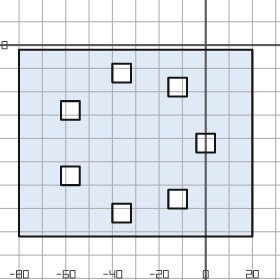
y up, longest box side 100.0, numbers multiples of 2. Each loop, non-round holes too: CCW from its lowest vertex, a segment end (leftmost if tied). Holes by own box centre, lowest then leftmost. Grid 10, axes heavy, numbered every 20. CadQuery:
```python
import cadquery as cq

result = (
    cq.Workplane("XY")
    .moveTo(-80.0, -82.0)
    .lineTo(20.0, -82.0)
    .lineTo(20.0, -2.0)
    .lineTo(-80.0, -2.0)
    .close()
    .moveTo(-40.0, -76.0)
    .lineTo(-32.0, -76.0)
    .lineTo(-32.0, -68.0)
    .lineTo(-40.0, -68.0)
    .close()
    .moveTo(-16.0, -70.0)
    .lineTo(-8.0, -70.0)
    .lineTo(-8.0, -62.0)
    .lineTo(-16.0, -62.0)
    .close()
    .moveTo(-62.0, -60.0)
    .lineTo(-54.0, -60.0)
    .lineTo(-54.0, -52.0)
    .lineTo(-62.0, -52.0)
    .close()
    .moveTo(-4.0, -46.0)
    .lineTo(4.0, -46.0)
    .lineTo(4.0, -38.0)
    .lineTo(-4.0, -38.0)
    .close()
    .moveTo(-62.0, -32.0)
    .lineTo(-54.0, -32.0)
    .lineTo(-54.0, -24.0)
    .lineTo(-62.0, -24.0)
    .close()
    .moveTo(-16.0, -22.0)
    .lineTo(-8.0, -22.0)
    .lineTo(-8.0, -14.0)
    .lineTo(-16.0, -14.0)
    .close()
    .moveTo(-40.0, -16.0)
    .lineTo(-32.0, -16.0)
    .lineTo(-32.0, -8.0)
    .lineTo(-40.0, -8.0)
    .close()
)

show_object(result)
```